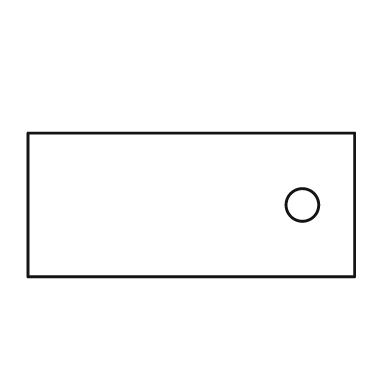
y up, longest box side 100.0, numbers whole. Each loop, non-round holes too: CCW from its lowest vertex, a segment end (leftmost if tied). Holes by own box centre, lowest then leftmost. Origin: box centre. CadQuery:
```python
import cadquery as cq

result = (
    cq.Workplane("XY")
    .moveTo(-50.0, -22.0)
    .lineTo(50.0, -22.0)
    .lineTo(50.0, 22.0)
    .lineTo(-50.0, 22.0)
    .close()
    .moveTo(34.0, 0.0)
    .circle(5.0)
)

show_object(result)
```